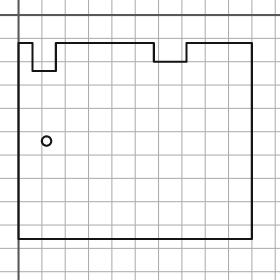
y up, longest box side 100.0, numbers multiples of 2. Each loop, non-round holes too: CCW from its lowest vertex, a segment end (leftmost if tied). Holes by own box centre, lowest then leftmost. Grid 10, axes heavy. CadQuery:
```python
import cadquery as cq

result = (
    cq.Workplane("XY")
    .moveTo(0.0, -96.0)
    .lineTo(100.0, -96.0)
    .lineTo(100.0, -12.0)
    .lineTo(72.0, -12.0)
    .lineTo(72.0, -20.0)
    .lineTo(58.0, -20.0)
    .lineTo(58.0, -12.0)
    .lineTo(16.0, -12.0)
    .lineTo(16.0, -24.0)
    .lineTo(6.0, -24.0)
    .lineTo(6.0, -12.0)
    .lineTo(0.0, -12.0)
    .close()
    .moveTo(12.0, -54.0)
    .circle(2.0)
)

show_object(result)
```